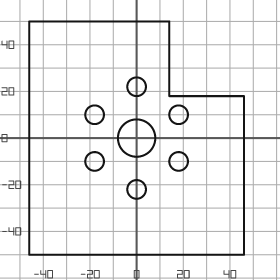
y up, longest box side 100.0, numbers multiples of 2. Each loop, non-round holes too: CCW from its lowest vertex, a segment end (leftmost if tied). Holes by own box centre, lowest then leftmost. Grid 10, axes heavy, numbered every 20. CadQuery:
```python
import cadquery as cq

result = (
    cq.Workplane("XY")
    .moveTo(-46.0, -50.0)
    .lineTo(46.0, -50.0)
    .lineTo(46.0, 18.0)
    .lineTo(14.0, 18.0)
    .lineTo(14.0, 50.0)
    .lineTo(-46.0, 50.0)
    .close()
    .moveTo(0.0, -22.0)
    .circle(4.0)
    .moveTo(-18.0, -10.0)
    .circle(4.0)
    .moveTo(18.0, -10.0)
    .circle(4.0)
    .moveTo(0.0, 0.0)
    .circle(8.0)
    .moveTo(-18.0, 10.0)
    .circle(4.0)
    .moveTo(18.0, 10.0)
    .circle(4.0)
    .moveTo(0.0, 22.0)
    .circle(4.0)
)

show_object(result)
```